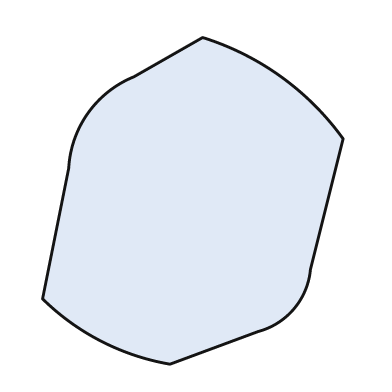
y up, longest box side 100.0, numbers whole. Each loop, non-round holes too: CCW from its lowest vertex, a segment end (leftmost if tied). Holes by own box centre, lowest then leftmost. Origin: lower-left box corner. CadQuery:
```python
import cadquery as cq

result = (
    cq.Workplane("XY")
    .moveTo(39.0, 0.0)
    .lineTo(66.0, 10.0)
    .threePointArc((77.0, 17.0), (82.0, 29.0))
    .lineTo(92.0, 69.0)
    .threePointArc((73.0, 88.0), (49.0, 100.0))
    .lineTo(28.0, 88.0)
    .threePointArc((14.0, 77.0), (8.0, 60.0))
    .lineTo(0.0, 20.0)
    .threePointArc((18.0, 7.0), (39.0, 0.0))
    .close()
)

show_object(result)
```